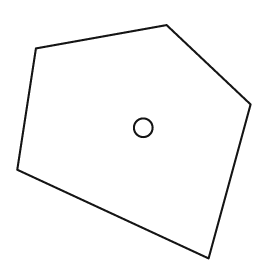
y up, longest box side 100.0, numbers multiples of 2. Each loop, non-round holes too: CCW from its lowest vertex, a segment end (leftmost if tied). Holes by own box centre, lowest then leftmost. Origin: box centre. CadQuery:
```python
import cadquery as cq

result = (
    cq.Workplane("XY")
    .moveTo(32.0, -50.0)
    .lineTo(50.0, 16.0)
    .lineTo(14.0, 50.0)
    .lineTo(-42.0, 40.0)
    .lineTo(-50.0, -12.0)
    .close()
    .moveTo(4.0, 6.0)
    .circle(4.0)
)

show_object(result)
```